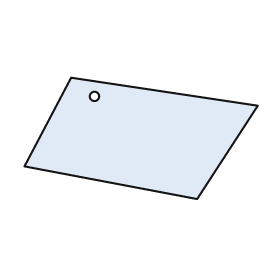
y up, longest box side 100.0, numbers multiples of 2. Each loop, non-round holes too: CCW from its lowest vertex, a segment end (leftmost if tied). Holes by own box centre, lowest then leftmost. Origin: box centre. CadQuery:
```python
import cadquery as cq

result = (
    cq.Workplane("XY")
    .moveTo(24.0, -26.0)
    .lineTo(50.0, 14.0)
    .lineTo(-30.0, 26.0)
    .lineTo(-50.0, -12.0)
    .close()
    .moveTo(-20.0, 18.0)
    .circle(2.0)
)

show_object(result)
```